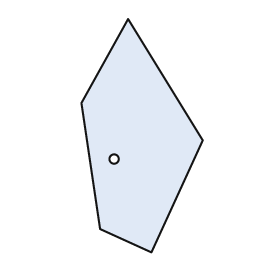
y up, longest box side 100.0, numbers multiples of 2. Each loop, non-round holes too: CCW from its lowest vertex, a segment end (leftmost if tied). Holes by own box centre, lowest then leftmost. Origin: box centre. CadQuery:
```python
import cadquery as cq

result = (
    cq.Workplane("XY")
    .moveTo(4.0, -50.0)
    .lineTo(26.0, -2.0)
    .lineTo(-6.0, 50.0)
    .lineTo(-26.0, 14.0)
    .lineTo(-18.0, -40.0)
    .close()
    .moveTo(-12.0, -10.0)
    .circle(2.0)
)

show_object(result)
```